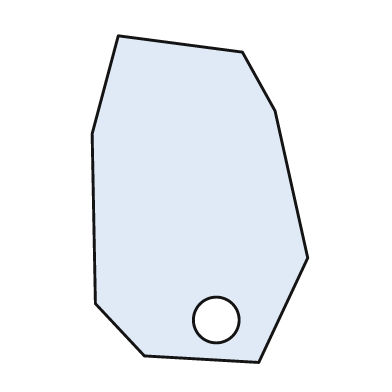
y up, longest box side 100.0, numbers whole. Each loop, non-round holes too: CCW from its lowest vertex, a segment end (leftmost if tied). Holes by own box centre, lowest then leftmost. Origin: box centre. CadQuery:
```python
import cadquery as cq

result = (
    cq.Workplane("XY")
    .moveTo(18.0, -50.0)
    .lineTo(33.0, -18.0)
    .lineTo(23.0, 27.0)
    .lineTo(13.0, 45.0)
    .lineTo(-25.0, 50.0)
    .lineTo(-33.0, 20.0)
    .lineTo(-32.0, -32.0)
    .lineTo(-17.0, -48.0)
    .close()
    .moveTo(5.0, -37.0)
    .circle(7.0)
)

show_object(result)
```